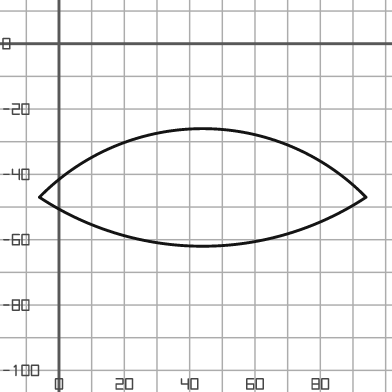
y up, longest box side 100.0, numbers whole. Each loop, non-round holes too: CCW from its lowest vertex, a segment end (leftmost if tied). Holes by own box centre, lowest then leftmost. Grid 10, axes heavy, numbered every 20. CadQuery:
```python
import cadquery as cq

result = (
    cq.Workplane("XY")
    .moveTo(-6.0, -47.0)
    .threePointArc((44.0, -62.0), (94.0, -47.0))
    .threePointArc((44.0, -26.0), (-6.0, -47.0))
    .close()
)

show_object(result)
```